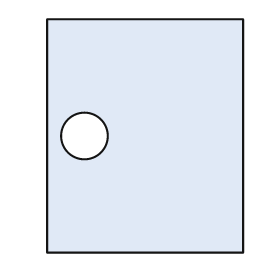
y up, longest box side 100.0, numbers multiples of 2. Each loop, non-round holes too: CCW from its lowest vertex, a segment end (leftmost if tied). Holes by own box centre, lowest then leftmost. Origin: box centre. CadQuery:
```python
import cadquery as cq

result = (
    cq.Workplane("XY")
    .moveTo(-42.0, -50.0)
    .lineTo(42.0, -50.0)
    .lineTo(42.0, 50.0)
    .lineTo(-42.0, 50.0)
    .close()
    .moveTo(-26.0, 0.0)
    .circle(10.0)
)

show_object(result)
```